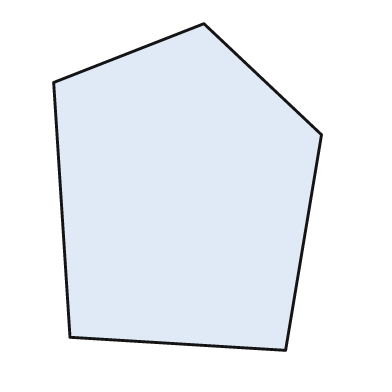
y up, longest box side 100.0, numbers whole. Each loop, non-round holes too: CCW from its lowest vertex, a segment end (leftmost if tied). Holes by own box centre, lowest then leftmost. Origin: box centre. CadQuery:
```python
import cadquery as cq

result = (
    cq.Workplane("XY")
    .moveTo(30.0, -50.0)
    .lineTo(41.0, 16.0)
    .lineTo(5.0, 50.0)
    .lineTo(-41.0, 32.0)
    .lineTo(-36.0, -46.0)
    .close()
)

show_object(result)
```